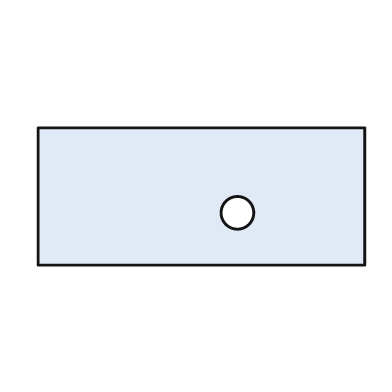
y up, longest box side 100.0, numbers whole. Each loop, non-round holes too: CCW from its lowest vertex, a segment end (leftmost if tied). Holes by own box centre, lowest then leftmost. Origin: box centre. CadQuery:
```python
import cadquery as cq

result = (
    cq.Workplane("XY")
    .moveTo(-50.0, -21.0)
    .lineTo(50.0, -21.0)
    .lineTo(50.0, 21.0)
    .lineTo(-50.0, 21.0)
    .close()
    .moveTo(11.0, -5.0)
    .circle(5.0)
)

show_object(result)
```